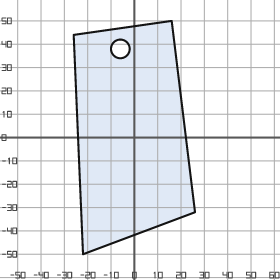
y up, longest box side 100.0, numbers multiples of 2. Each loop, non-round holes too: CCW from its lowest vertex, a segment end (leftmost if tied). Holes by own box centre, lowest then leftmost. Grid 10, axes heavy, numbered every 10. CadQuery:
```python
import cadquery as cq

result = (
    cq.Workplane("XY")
    .moveTo(-22.0, -50.0)
    .lineTo(26.0, -32.0)
    .lineTo(16.0, 50.0)
    .lineTo(-26.0, 44.0)
    .close()
    .moveTo(-6.0, 38.0)
    .circle(4.0)
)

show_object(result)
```